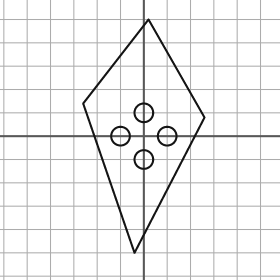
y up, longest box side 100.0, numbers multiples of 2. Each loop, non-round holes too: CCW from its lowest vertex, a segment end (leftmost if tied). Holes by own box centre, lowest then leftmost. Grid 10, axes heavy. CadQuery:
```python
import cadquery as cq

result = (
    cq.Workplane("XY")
    .moveTo(-4.0, -50.0)
    .lineTo(26.0, 8.0)
    .lineTo(2.0, 50.0)
    .lineTo(-26.0, 14.0)
    .close()
    .moveTo(0.0, -10.0)
    .circle(4.0)
    .moveTo(-10.0, 0.0)
    .circle(4.0)
    .moveTo(10.0, 0.0)
    .circle(4.0)
    .moveTo(0.0, 10.0)
    .circle(4.0)
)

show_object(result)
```